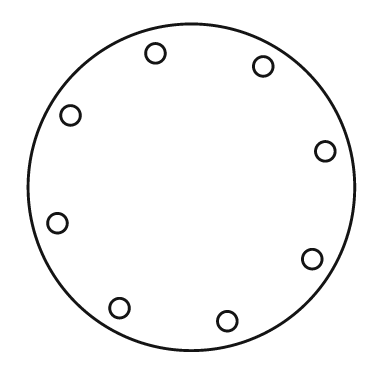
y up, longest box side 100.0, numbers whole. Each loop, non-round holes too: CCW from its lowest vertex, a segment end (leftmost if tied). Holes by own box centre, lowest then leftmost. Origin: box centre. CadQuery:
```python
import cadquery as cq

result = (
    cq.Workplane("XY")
    .moveTo(0.0, 0.0)
    .circle(50.0)
    .moveTo(11.0, -41.0)
    .circle(3.0)
    .moveTo(-22.0, -37.0)
    .circle(3.0)
    .moveTo(37.0, -22.0)
    .circle(3.0)
    .moveTo(-41.0, -11.0)
    .circle(3.0)
    .moveTo(41.0, 11.0)
    .circle(3.0)
    .moveTo(-37.0, 22.0)
    .circle(3.0)
    .moveTo(22.0, 37.0)
    .circle(3.0)
    .moveTo(-11.0, 41.0)
    .circle(3.0)
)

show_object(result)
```